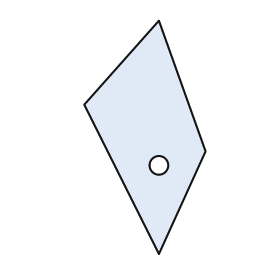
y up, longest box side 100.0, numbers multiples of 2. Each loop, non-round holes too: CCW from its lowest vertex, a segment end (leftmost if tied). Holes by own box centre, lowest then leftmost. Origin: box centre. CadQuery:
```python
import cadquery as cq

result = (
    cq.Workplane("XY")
    .moveTo(6.0, -50.0)
    .lineTo(26.0, -6.0)
    .lineTo(6.0, 50.0)
    .lineTo(-26.0, 14.0)
    .close()
    .moveTo(6.0, -12.0)
    .circle(4.0)
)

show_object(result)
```